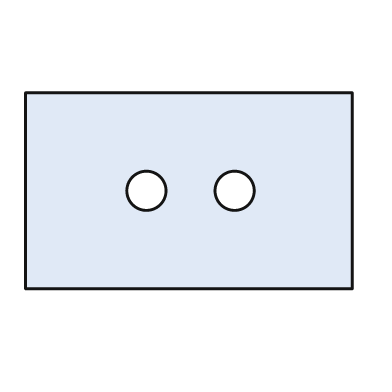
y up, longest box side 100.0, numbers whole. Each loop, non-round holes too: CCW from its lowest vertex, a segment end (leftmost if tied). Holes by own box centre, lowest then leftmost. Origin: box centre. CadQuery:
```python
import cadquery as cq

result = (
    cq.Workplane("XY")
    .moveTo(-50.0, -30.0)
    .lineTo(50.0, -30.0)
    .lineTo(50.0, 30.0)
    .lineTo(-50.0, 30.0)
    .close()
    .moveTo(-13.0, 0.0)
    .circle(6.0)
    .moveTo(14.0, 0.0)
    .circle(6.0)
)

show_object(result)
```